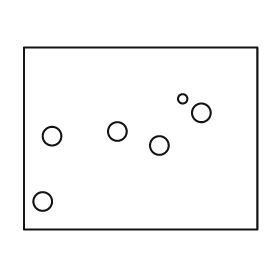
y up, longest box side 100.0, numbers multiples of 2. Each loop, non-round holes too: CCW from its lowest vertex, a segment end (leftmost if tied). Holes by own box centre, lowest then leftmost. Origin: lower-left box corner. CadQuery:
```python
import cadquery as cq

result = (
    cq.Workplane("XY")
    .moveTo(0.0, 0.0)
    .lineTo(100.0, 0.0)
    .lineTo(100.0, 78.0)
    .lineTo(0.0, 78.0)
    .close()
    .moveTo(8.0, 12.0)
    .circle(4.0)
    .moveTo(58.0, 36.0)
    .circle(4.0)
    .moveTo(12.0, 40.0)
    .circle(4.0)
    .moveTo(40.0, 42.0)
    .circle(4.0)
    .moveTo(76.0, 50.0)
    .circle(4.0)
    .moveTo(68.0, 56.0)
    .circle(2.0)
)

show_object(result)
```